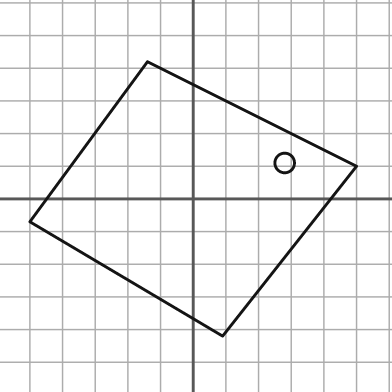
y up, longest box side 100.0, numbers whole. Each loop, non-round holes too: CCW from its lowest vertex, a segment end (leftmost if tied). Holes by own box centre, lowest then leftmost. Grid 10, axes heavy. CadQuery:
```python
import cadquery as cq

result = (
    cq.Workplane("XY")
    .moveTo(9.0, -42.0)
    .lineTo(50.0, 10.0)
    .lineTo(-14.0, 42.0)
    .lineTo(-50.0, -7.0)
    .close()
    .moveTo(28.0, 11.0)
    .circle(3.0)
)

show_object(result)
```